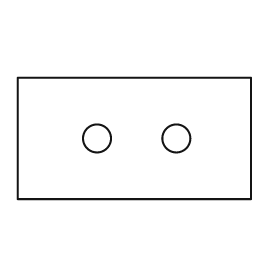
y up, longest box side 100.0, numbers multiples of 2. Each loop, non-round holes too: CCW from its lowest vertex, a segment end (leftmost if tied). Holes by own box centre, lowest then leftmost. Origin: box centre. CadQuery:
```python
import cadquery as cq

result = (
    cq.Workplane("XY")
    .moveTo(-50.0, -26.0)
    .lineTo(50.0, -26.0)
    .lineTo(50.0, 26.0)
    .lineTo(-50.0, 26.0)
    .close()
    .moveTo(-16.0, 0.0)
    .circle(6.0)
    .moveTo(18.0, 0.0)
    .circle(6.0)
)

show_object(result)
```